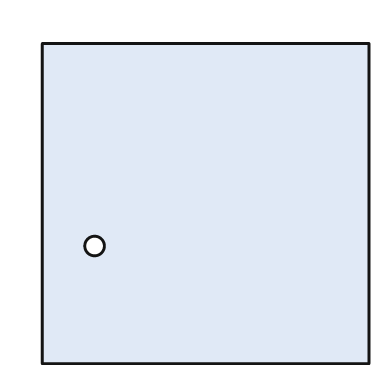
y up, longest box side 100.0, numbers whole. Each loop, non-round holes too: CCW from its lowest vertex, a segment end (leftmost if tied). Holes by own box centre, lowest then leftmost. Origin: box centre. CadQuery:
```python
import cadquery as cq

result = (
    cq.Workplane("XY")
    .moveTo(-50.0, -49.0)
    .lineTo(50.0, -49.0)
    .lineTo(50.0, 49.0)
    .lineTo(-50.0, 49.0)
    .close()
    .moveTo(-34.0, -13.0)
    .circle(3.0)
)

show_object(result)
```